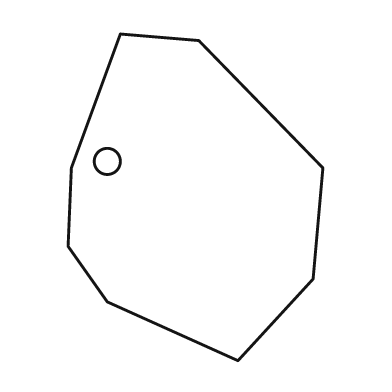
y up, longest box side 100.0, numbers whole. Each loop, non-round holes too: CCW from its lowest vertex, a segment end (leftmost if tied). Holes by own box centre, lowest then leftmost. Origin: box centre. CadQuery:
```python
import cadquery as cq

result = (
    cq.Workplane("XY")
    .moveTo(13.0, -50.0)
    .lineTo(36.0, -25.0)
    .lineTo(39.0, 9.0)
    .lineTo(1.0, 48.0)
    .lineTo(-23.0, 50.0)
    .lineTo(-38.0, 9.0)
    .lineTo(-39.0, -15.0)
    .lineTo(-27.0, -32.0)
    .close()
    .moveTo(-27.0, 11.0)
    .circle(4.0)
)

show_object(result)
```